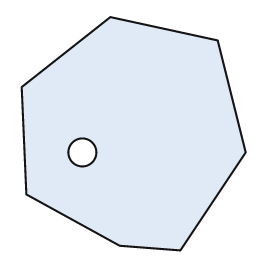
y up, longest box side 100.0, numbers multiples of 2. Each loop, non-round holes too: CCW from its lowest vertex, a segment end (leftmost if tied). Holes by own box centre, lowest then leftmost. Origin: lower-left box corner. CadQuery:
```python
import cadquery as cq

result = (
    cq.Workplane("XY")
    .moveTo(68.0, 0.0)
    .lineTo(96.0, 42.0)
    .lineTo(84.0, 90.0)
    .lineTo(38.0, 100.0)
    .lineTo(0.0, 70.0)
    .lineTo(2.0, 24.0)
    .lineTo(42.0, 2.0)
    .close()
    .moveTo(26.0, 42.0)
    .circle(6.0)
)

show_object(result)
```